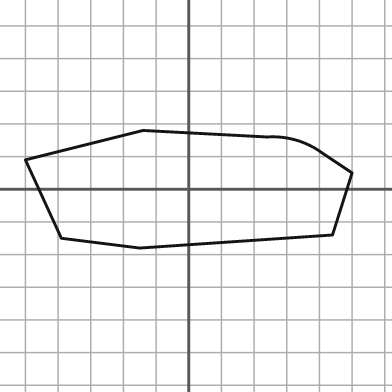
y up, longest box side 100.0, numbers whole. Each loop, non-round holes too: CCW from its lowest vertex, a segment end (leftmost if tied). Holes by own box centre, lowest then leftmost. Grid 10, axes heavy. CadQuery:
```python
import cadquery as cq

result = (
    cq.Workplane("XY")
    .moveTo(-15.0, -18.0)
    .lineTo(44.0, -14.0)
    .lineTo(50.0, 5.0)
    .lineTo(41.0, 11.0)
    .threePointArc((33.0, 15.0), (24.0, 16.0))
    .lineTo(-14.0, 18.0)
    .lineTo(-50.0, 9.0)
    .lineTo(-39.0, -15.0)
    .close()
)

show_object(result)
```